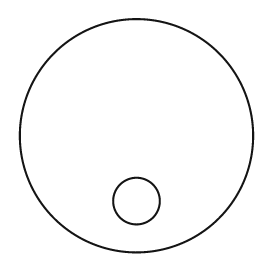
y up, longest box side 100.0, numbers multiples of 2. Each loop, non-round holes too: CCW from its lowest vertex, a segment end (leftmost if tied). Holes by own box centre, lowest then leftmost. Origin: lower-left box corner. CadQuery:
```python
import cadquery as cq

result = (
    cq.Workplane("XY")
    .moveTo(50.0, 50.0)
    .circle(50.0)
    .moveTo(50.0, 22.0)
    .circle(10.0)
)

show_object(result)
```